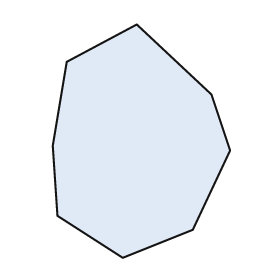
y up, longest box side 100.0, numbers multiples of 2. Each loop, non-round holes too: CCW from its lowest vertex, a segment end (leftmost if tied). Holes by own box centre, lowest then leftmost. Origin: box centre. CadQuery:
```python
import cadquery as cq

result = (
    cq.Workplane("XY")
    .moveTo(-8.0, -50.0)
    .lineTo(22.0, -38.0)
    .lineTo(38.0, -4.0)
    .lineTo(30.0, 20.0)
    .lineTo(-2.0, 50.0)
    .lineTo(-32.0, 34.0)
    .lineTo(-38.0, -2.0)
    .lineTo(-36.0, -32.0)
    .close()
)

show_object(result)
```